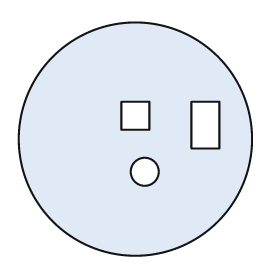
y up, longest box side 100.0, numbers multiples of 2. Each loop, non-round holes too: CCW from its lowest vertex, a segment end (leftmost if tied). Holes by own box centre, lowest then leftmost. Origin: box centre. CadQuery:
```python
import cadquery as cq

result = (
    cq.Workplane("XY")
    .moveTo(0.0, 0.0)
    .circle(50.0)
    .moveTo(4.0, -14.0)
    .circle(6.0)
    .moveTo(24.0, -4.0)
    .lineTo(36.0, -4.0)
    .lineTo(36.0, 16.0)
    .lineTo(24.0, 16.0)
    .close()
    .moveTo(-6.0, 4.0)
    .lineTo(6.0, 4.0)
    .lineTo(6.0, 16.0)
    .lineTo(-6.0, 16.0)
    .close()
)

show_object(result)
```